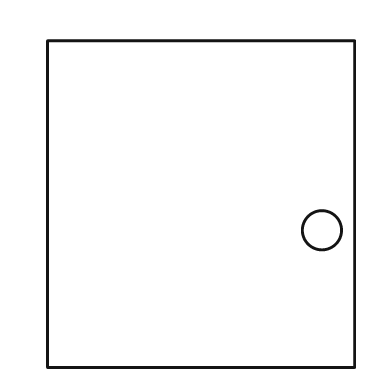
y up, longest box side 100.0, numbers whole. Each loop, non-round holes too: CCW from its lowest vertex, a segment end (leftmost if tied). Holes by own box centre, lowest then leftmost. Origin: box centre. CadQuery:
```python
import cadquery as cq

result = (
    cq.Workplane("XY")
    .moveTo(-47.0, -50.0)
    .lineTo(47.0, -50.0)
    .lineTo(47.0, 50.0)
    .lineTo(-47.0, 50.0)
    .close()
    .moveTo(37.0, -8.0)
    .circle(6.0)
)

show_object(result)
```